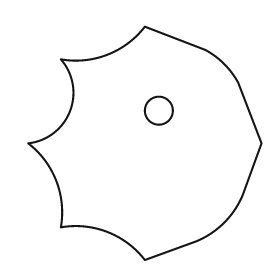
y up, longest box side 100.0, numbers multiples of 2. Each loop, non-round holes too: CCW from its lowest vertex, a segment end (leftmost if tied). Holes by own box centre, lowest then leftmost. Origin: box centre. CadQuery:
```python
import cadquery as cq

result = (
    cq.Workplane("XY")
    .moveTo(0.0, -50.0)
    .lineTo(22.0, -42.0)
    .threePointArc((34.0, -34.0), (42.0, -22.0))
    .lineTo(50.0, 0.0)
    .lineTo(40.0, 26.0)
    .threePointArc((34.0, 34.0), (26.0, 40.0))
    .lineTo(0.0, 50.0)
    .threePointArc((-16.0, 38.0), (-36.0, 36.0))
    .threePointArc((-32.0, 14.0), (-50.0, 0.0))
    .threePointArc((-38.0, -16.0), (-36.0, -36.0))
    .threePointArc((-16.0, -38.0), (0.0, -50.0))
    .close()
    .moveTo(6.0, 14.0)
    .circle(6.0)
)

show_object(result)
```